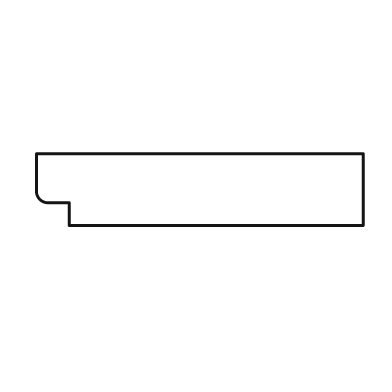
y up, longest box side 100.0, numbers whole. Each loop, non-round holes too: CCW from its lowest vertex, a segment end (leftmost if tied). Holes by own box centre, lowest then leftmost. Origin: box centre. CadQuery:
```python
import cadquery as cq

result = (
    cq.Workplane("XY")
    .moveTo(-40.0, -11.0)
    .lineTo(50.0, -11.0)
    .lineTo(50.0, 11.0)
    .lineTo(-50.0, 11.0)
    .lineTo(-50.0, 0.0)
    .threePointArc((-49.0, -3.0), (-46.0, -4.0))
    .lineTo(-40.0, -4.0)
    .close()
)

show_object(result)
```